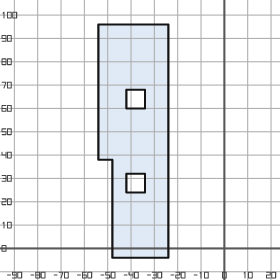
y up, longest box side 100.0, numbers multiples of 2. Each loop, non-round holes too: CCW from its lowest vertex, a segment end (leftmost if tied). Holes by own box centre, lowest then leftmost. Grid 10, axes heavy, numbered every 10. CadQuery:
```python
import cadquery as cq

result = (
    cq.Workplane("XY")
    .moveTo(-48.0, -4.0)
    .lineTo(-24.0, -4.0)
    .lineTo(-24.0, 96.0)
    .lineTo(-54.0, 96.0)
    .lineTo(-54.0, 38.0)
    .lineTo(-48.0, 38.0)
    .close()
    .moveTo(-42.0, 24.0)
    .lineTo(-34.0, 24.0)
    .lineTo(-34.0, 32.0)
    .lineTo(-42.0, 32.0)
    .close()
    .moveTo(-42.0, 60.0)
    .lineTo(-34.0, 60.0)
    .lineTo(-34.0, 68.0)
    .lineTo(-42.0, 68.0)
    .close()
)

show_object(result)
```